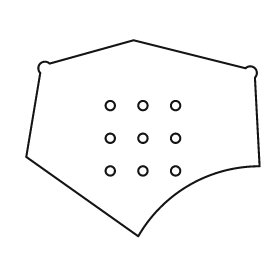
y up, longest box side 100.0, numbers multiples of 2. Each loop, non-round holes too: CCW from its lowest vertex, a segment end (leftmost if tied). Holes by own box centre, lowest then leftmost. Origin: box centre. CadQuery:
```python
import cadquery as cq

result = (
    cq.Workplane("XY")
    .moveTo(-2.0, -42.0)
    .threePointArc((20.0, -20.0), (50.0, -12.0))
    .lineTo(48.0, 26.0)
    .threePointArc((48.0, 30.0), (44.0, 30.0))
    .lineTo(-4.0, 42.0)
    .lineTo(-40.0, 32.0)
    .threePointArc((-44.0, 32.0), (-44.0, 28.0))
    .lineTo(-50.0, -8.0)
    .close()
    .moveTo(-14.0, -14.0)
    .circle(2.0)
    .moveTo(0.0, -14.0)
    .circle(2.0)
    .moveTo(14.0, -14.0)
    .circle(2.0)
    .moveTo(-14.0, 0.0)
    .circle(2.0)
    .moveTo(0.0, 0.0)
    .circle(2.0)
    .moveTo(14.0, 0.0)
    .circle(2.0)
    .moveTo(-14.0, 14.0)
    .circle(2.0)
    .moveTo(0.0, 14.0)
    .circle(2.0)
    .moveTo(14.0, 14.0)
    .circle(2.0)
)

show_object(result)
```